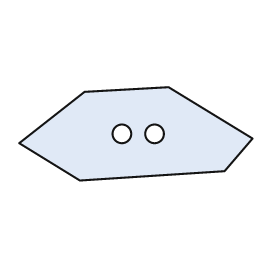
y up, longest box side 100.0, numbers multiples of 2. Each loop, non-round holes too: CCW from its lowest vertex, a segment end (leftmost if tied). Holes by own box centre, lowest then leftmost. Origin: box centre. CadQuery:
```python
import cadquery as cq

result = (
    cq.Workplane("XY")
    .moveTo(-24.0, -20.0)
    .lineTo(38.0, -16.0)
    .lineTo(50.0, -2.0)
    .lineTo(14.0, 20.0)
    .lineTo(-22.0, 18.0)
    .lineTo(-50.0, -4.0)
    .close()
    .moveTo(-6.0, 0.0)
    .circle(4.0)
    .moveTo(8.0, 0.0)
    .circle(4.0)
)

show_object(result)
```